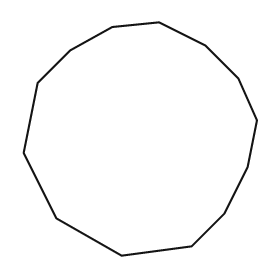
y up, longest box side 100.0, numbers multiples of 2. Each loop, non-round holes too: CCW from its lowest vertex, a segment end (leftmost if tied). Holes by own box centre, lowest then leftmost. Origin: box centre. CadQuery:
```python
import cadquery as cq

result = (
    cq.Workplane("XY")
    .moveTo(-8.0, -50.0)
    .lineTo(22.0, -46.0)
    .lineTo(36.0, -32.0)
    .lineTo(46.0, -12.0)
    .lineTo(50.0, 8.0)
    .lineTo(42.0, 26.0)
    .lineTo(28.0, 40.0)
    .lineTo(8.0, 50.0)
    .lineTo(-12.0, 48.0)
    .lineTo(-30.0, 38.0)
    .lineTo(-44.0, 24.0)
    .lineTo(-50.0, -6.0)
    .lineTo(-36.0, -34.0)
    .close()
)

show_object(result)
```